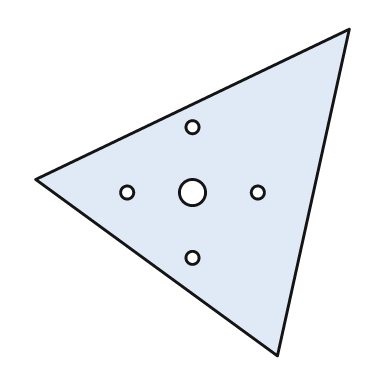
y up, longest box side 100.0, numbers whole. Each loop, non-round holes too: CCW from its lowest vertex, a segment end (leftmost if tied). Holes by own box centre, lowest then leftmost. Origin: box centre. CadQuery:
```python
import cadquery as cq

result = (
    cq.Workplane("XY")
    .moveTo(26.0, -50.0)
    .lineTo(48.0, 50.0)
    .lineTo(-48.0, 4.0)
    .close()
    .moveTo(0.0, -20.0)
    .circle(2.0)
    .moveTo(-20.0, 0.0)
    .circle(2.0)
    .moveTo(0.0, 0.0)
    .circle(4.0)
    .moveTo(20.0, 0.0)
    .circle(2.0)
    .moveTo(0.0, 20.0)
    .circle(2.0)
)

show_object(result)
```